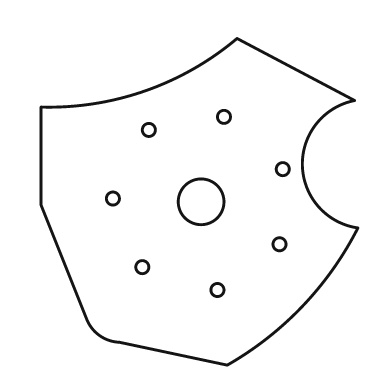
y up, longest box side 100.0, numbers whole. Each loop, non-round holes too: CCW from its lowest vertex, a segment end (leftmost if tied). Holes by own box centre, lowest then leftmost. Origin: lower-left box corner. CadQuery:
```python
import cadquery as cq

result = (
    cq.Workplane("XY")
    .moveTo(57.0, 0.0)
    .threePointArc((80.0, 18.0), (97.0, 42.0))
    .threePointArc((80.0, 61.0), (96.0, 81.0))
    .lineTo(60.0, 100.0)
    .threePointArc((32.0, 84.0), (0.0, 79.0))
    .lineTo(0.0, 49.0)
    .lineTo(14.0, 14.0)
    .threePointArc((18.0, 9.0), (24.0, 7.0))
    .close()
    .moveTo(54.0, 23.0)
    .circle(2.0)
    .moveTo(31.0, 30.0)
    .circle(2.0)
    .moveTo(73.0, 37.0)
    .circle(2.0)
    .moveTo(49.0, 50.0)
    .circle(7.0)
    .moveTo(22.0, 51.0)
    .circle(2.0)
    .moveTo(74.0, 60.0)
    .circle(2.0)
    .moveTo(33.0, 72.0)
    .circle(2.0)
    .moveTo(56.0, 76.0)
    .circle(2.0)
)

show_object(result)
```